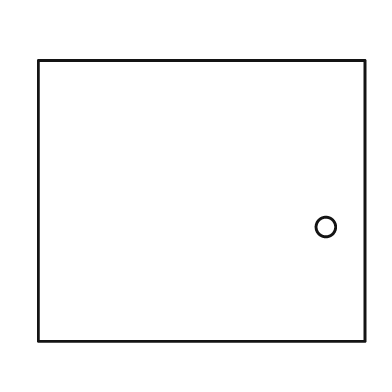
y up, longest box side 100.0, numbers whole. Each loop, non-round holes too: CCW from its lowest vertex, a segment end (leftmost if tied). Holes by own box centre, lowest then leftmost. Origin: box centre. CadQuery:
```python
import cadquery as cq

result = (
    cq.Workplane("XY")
    .moveTo(-50.0, -43.0)
    .lineTo(50.0, -43.0)
    .lineTo(50.0, 43.0)
    .lineTo(-50.0, 43.0)
    .close()
    .moveTo(38.0, -8.0)
    .circle(3.0)
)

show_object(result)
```